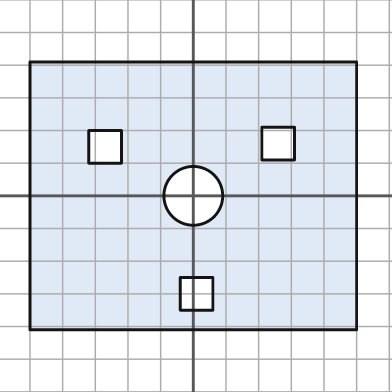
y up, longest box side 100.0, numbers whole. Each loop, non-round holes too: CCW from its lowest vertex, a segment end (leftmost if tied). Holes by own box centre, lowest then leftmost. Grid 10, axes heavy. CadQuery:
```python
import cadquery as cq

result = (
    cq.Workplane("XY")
    .moveTo(-50.0, -41.0)
    .lineTo(50.0, -41.0)
    .lineTo(50.0, 41.0)
    .lineTo(-50.0, 41.0)
    .close()
    .moveTo(-4.0, -35.0)
    .lineTo(6.0, -35.0)
    .lineTo(6.0, -25.0)
    .lineTo(-4.0, -25.0)
    .close()
    .moveTo(0.0, 0.0)
    .circle(9.0)
    .moveTo(-32.0, 10.0)
    .lineTo(-22.0, 10.0)
    .lineTo(-22.0, 20.0)
    .lineTo(-32.0, 20.0)
    .close()
    .moveTo(21.0, 11.0)
    .lineTo(31.0, 11.0)
    .lineTo(31.0, 21.0)
    .lineTo(21.0, 21.0)
    .close()
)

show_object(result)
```